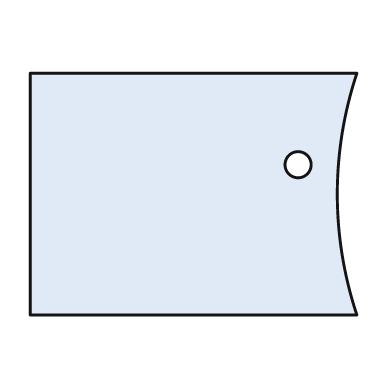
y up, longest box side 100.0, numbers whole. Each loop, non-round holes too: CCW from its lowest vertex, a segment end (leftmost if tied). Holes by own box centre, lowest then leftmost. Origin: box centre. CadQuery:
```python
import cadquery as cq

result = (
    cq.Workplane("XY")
    .moveTo(-50.0, -37.0)
    .lineTo(50.0, -37.0)
    .threePointArc((44.0, 0.0), (50.0, 37.0))
    .lineTo(-50.0, 37.0)
    .close()
    .moveTo(32.0, 9.0)
    .circle(4.0)
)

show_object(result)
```